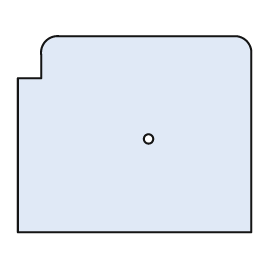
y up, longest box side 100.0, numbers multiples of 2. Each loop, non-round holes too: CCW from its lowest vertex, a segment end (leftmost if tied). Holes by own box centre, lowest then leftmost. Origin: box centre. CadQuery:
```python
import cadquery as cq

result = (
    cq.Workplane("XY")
    .moveTo(-50.0, -42.0)
    .lineTo(50.0, -42.0)
    .lineTo(50.0, 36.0)
    .threePointArc((48.0, 40.0), (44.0, 42.0))
    .lineTo(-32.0, 42.0)
    .threePointArc((-38.0, 40.0), (-40.0, 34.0))
    .lineTo(-40.0, 24.0)
    .lineTo(-50.0, 24.0)
    .close()
    .moveTo(6.0, -2.0)
    .circle(2.0)
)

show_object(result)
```